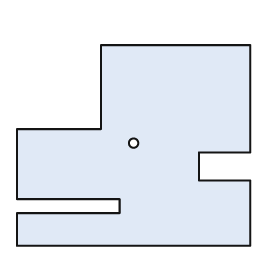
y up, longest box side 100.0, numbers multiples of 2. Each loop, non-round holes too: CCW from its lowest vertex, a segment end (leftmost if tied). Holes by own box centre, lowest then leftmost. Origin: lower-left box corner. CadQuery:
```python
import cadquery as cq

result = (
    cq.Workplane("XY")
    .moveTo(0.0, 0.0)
    .lineTo(100.0, 0.0)
    .lineTo(100.0, 28.0)
    .lineTo(78.0, 28.0)
    .lineTo(78.0, 40.0)
    .lineTo(100.0, 40.0)
    .lineTo(100.0, 86.0)
    .lineTo(36.0, 86.0)
    .lineTo(36.0, 50.0)
    .lineTo(0.0, 50.0)
    .lineTo(0.0, 20.0)
    .lineTo(44.0, 20.0)
    .lineTo(44.0, 14.0)
    .lineTo(0.0, 14.0)
    .close()
    .moveTo(50.0, 44.0)
    .circle(2.0)
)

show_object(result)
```